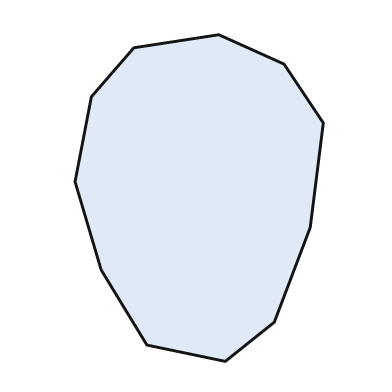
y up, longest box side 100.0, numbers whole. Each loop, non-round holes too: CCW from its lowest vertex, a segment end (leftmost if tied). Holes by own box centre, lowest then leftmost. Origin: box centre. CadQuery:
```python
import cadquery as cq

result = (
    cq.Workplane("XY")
    .moveTo(8.0, -50.0)
    .lineTo(23.0, -38.0)
    .lineTo(34.0, -9.0)
    .lineTo(38.0, 23.0)
    .lineTo(26.0, 41.0)
    .lineTo(6.0, 50.0)
    .lineTo(-20.0, 46.0)
    .lineTo(-33.0, 31.0)
    .lineTo(-38.0, 5.0)
    .lineTo(-30.0, -22.0)
    .lineTo(-16.0, -45.0)
    .close()
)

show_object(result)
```